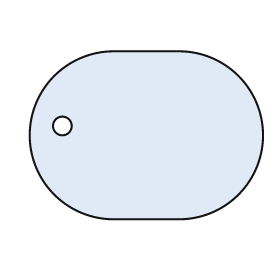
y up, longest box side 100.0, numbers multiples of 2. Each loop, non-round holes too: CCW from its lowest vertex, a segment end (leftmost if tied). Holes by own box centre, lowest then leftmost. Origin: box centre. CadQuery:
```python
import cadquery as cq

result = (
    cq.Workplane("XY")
    .moveTo(-14.0, -36.0)
    .lineTo(14.0, -36.0)
    .threePointArc((50.0, 0.0), (14.0, 36.0))
    .lineTo(-14.0, 36.0)
    .threePointArc((-50.0, 0.0), (-14.0, -36.0))
    .close()
    .moveTo(-36.0, 4.0)
    .circle(4.0)
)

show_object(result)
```